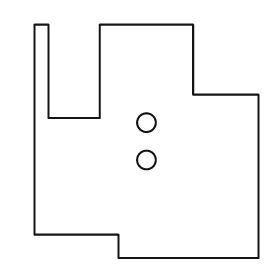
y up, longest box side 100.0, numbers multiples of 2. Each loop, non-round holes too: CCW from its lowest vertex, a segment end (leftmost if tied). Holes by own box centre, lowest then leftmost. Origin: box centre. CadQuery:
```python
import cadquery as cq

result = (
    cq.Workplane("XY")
    .moveTo(-12.0, -50.0)
    .lineTo(48.0, -50.0)
    .lineTo(48.0, 20.0)
    .lineTo(20.0, 20.0)
    .lineTo(20.0, 50.0)
    .lineTo(-20.0, 50.0)
    .lineTo(-20.0, 10.0)
    .lineTo(-42.0, 10.0)
    .lineTo(-42.0, 50.0)
    .lineTo(-48.0, 50.0)
    .lineTo(-48.0, -40.0)
    .lineTo(-12.0, -40.0)
    .close()
    .moveTo(0.0, -8.0)
    .circle(4.0)
    .moveTo(0.0, 8.0)
    .circle(4.0)
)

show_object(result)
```